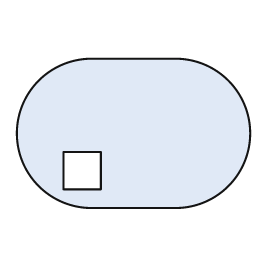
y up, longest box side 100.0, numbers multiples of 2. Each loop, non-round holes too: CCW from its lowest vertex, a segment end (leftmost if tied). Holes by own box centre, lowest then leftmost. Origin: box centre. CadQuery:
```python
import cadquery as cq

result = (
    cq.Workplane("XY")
    .moveTo(-18.0, -32.0)
    .lineTo(18.0, -32.0)
    .threePointArc((50.0, 0.0), (18.0, 32.0))
    .lineTo(-18.0, 32.0)
    .threePointArc((-50.0, 0.0), (-18.0, -32.0))
    .close()
    .moveTo(-30.0, -24.0)
    .lineTo(-14.0, -24.0)
    .lineTo(-14.0, -8.0)
    .lineTo(-30.0, -8.0)
    .close()
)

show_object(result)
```